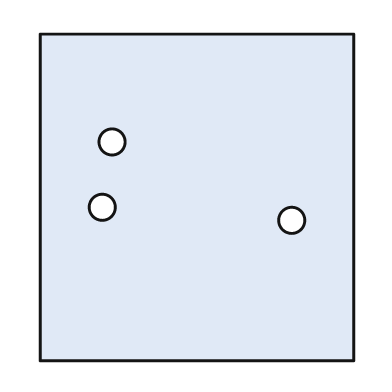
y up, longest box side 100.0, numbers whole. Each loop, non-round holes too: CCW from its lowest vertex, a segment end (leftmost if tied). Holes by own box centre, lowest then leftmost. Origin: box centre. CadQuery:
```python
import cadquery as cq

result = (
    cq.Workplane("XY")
    .moveTo(-48.0, -50.0)
    .lineTo(48.0, -50.0)
    .lineTo(48.0, 50.0)
    .lineTo(-48.0, 50.0)
    .close()
    .moveTo(29.0, -7.0)
    .circle(4.0)
    .moveTo(-29.0, -3.0)
    .circle(4.0)
    .moveTo(-26.0, 17.0)
    .circle(4.0)
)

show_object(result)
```